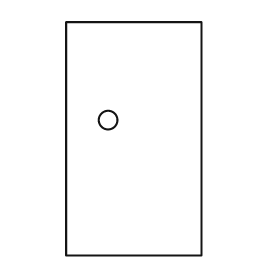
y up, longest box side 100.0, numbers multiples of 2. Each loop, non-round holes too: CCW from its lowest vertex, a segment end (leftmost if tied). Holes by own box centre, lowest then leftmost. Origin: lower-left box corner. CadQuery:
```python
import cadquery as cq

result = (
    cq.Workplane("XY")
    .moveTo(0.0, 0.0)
    .lineTo(58.0, 0.0)
    .lineTo(58.0, 100.0)
    .lineTo(0.0, 100.0)
    .close()
    .moveTo(18.0, 58.0)
    .circle(4.0)
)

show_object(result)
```